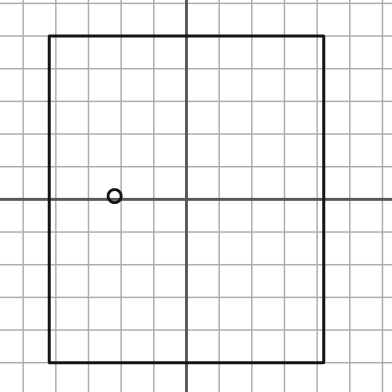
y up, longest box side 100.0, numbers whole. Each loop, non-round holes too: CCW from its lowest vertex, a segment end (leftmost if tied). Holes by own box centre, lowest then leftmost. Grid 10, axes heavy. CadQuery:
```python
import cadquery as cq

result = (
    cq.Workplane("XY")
    .moveTo(-42.0, -50.0)
    .lineTo(42.0, -50.0)
    .lineTo(42.0, 50.0)
    .lineTo(-42.0, 50.0)
    .close()
    .moveTo(-22.0, 1.0)
    .circle(2.0)
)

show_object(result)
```